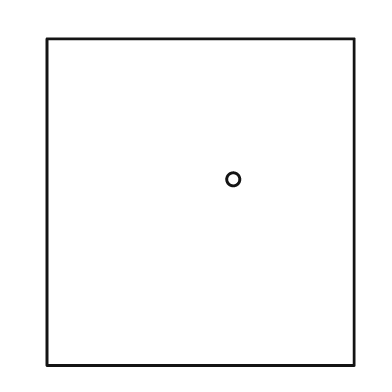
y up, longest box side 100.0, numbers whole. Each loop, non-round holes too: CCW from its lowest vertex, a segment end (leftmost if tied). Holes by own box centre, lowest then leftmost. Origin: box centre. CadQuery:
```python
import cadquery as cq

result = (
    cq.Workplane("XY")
    .moveTo(-47.0, -50.0)
    .lineTo(47.0, -50.0)
    .lineTo(47.0, 50.0)
    .lineTo(-47.0, 50.0)
    .close()
    .moveTo(10.0, 7.0)
    .circle(2.0)
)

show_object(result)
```